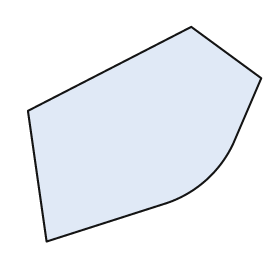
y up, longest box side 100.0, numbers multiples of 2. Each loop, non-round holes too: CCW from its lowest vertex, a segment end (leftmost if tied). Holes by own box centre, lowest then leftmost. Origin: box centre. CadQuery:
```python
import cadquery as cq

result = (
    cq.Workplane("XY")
    .moveTo(-42.0, -46.0)
    .lineTo(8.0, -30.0)
    .threePointArc((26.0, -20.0), (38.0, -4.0))
    .lineTo(50.0, 24.0)
    .lineTo(20.0, 46.0)
    .lineTo(-50.0, 10.0)
    .close()
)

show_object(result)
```